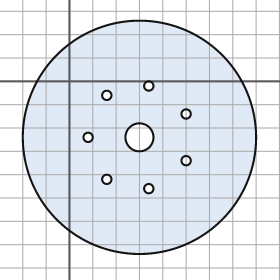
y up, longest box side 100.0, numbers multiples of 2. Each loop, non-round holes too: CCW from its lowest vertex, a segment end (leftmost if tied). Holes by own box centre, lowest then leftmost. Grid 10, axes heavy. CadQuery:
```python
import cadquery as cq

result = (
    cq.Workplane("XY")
    .moveTo(30.0, -24.0)
    .circle(50.0)
    .moveTo(34.0, -46.0)
    .circle(2.0)
    .moveTo(16.0, -42.0)
    .circle(2.0)
    .moveTo(50.0, -34.0)
    .circle(2.0)
    .moveTo(8.0, -24.0)
    .circle(2.0)
    .moveTo(30.0, -24.0)
    .circle(6.0)
    .moveTo(50.0, -14.0)
    .circle(2.0)
    .moveTo(16.0, -6.0)
    .circle(2.0)
    .moveTo(34.0, -2.0)
    .circle(2.0)
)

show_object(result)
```